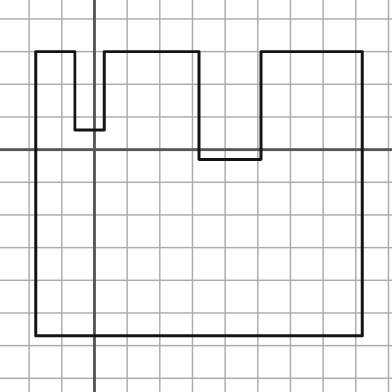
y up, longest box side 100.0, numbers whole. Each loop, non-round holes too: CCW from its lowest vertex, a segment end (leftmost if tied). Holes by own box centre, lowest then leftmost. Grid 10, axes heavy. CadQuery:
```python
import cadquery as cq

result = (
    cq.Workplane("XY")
    .moveTo(-18.0, -57.0)
    .lineTo(82.0, -57.0)
    .lineTo(82.0, 30.0)
    .lineTo(51.0, 30.0)
    .lineTo(51.0, -3.0)
    .lineTo(32.0, -3.0)
    .lineTo(32.0, 30.0)
    .lineTo(3.0, 30.0)
    .lineTo(3.0, 6.0)
    .lineTo(-6.0, 6.0)
    .lineTo(-6.0, 30.0)
    .lineTo(-18.0, 30.0)
    .close()
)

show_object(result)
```